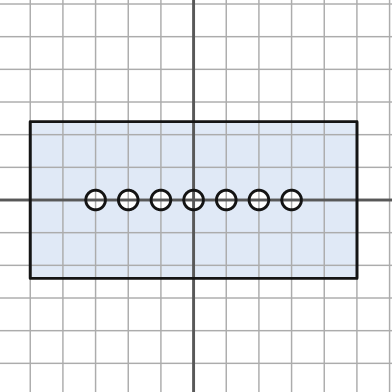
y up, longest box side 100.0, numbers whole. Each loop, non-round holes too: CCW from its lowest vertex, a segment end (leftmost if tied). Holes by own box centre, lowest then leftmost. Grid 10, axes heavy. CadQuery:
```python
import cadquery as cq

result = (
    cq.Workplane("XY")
    .moveTo(-50.0, -24.0)
    .lineTo(50.0, -24.0)
    .lineTo(50.0, 24.0)
    .lineTo(-50.0, 24.0)
    .close()
    .moveTo(-30.0, 0.0)
    .circle(3.0)
    .moveTo(-20.0, 0.0)
    .circle(3.0)
    .moveTo(-10.0, 0.0)
    .circle(3.0)
    .moveTo(0.0, 0.0)
    .circle(3.0)
    .moveTo(10.0, 0.0)
    .circle(3.0)
    .moveTo(20.0, 0.0)
    .circle(3.0)
    .moveTo(30.0, 0.0)
    .circle(3.0)
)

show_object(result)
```